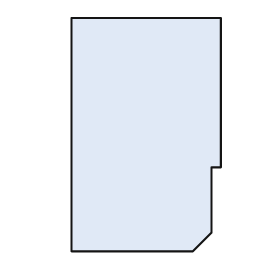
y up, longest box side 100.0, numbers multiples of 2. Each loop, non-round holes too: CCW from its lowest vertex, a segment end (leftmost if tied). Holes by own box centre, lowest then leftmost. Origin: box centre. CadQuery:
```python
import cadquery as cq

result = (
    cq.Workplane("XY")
    .moveTo(-32.0, -50.0)
    .lineTo(20.0, -50.0)
    .lineTo(28.0, -42.0)
    .lineTo(28.0, -14.0)
    .lineTo(32.0, -14.0)
    .lineTo(32.0, 50.0)
    .lineTo(-32.0, 50.0)
    .close()
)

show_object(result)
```